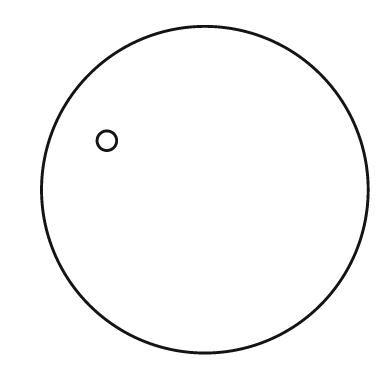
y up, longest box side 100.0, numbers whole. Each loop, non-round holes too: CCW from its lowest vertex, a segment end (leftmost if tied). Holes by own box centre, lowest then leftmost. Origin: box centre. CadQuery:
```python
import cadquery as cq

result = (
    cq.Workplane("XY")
    .moveTo(0.0, 0.0)
    .circle(50.0)
    .moveTo(-30.0, 15.0)
    .circle(3.0)
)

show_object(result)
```